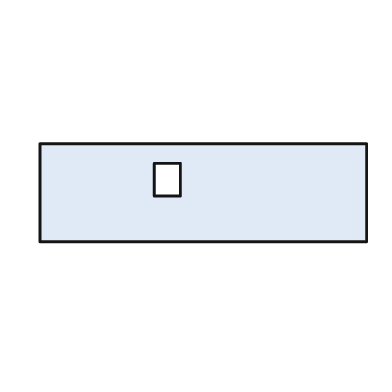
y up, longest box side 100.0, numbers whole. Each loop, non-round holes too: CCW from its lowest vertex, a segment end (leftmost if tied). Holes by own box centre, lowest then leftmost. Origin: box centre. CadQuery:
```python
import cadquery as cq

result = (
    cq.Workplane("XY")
    .moveTo(-50.0, -15.0)
    .lineTo(50.0, -15.0)
    .lineTo(50.0, 15.0)
    .lineTo(-50.0, 15.0)
    .close()
    .moveTo(-15.0, -1.0)
    .lineTo(-7.0, -1.0)
    .lineTo(-7.0, 9.0)
    .lineTo(-15.0, 9.0)
    .close()
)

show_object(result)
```